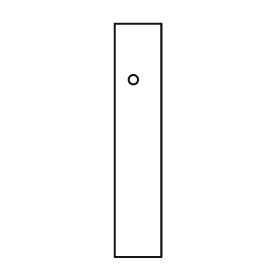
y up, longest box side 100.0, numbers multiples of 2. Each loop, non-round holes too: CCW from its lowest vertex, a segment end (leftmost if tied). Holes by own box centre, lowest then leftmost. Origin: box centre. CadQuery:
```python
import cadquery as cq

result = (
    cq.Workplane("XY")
    .moveTo(-10.0, -50.0)
    .lineTo(10.0, -50.0)
    .lineTo(10.0, 50.0)
    .lineTo(-10.0, 50.0)
    .close()
    .moveTo(-2.0, 26.0)
    .circle(2.0)
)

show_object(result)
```